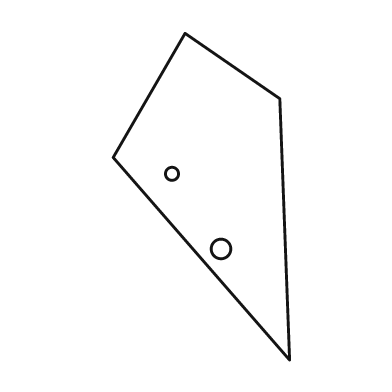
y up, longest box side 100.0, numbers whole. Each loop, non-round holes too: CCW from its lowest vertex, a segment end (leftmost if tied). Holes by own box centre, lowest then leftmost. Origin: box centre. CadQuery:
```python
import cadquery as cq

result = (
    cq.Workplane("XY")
    .moveTo(27.0, -50.0)
    .lineTo(24.0, 30.0)
    .lineTo(-5.0, 50.0)
    .lineTo(-27.0, 12.0)
    .close()
    .moveTo(6.0, -16.0)
    .circle(3.0)
    .moveTo(-9.0, 7.0)
    .circle(2.0)
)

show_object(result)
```